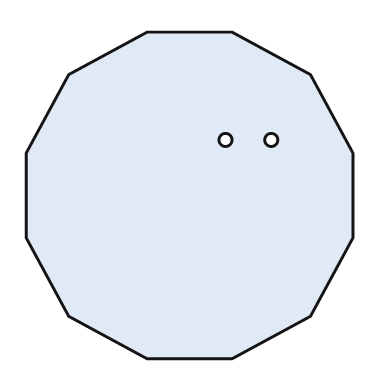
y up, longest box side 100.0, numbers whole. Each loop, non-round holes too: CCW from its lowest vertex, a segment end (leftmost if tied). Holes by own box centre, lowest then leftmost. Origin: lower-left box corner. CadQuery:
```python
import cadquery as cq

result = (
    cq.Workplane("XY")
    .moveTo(37.0, 0.0)
    .lineTo(63.0, 0.0)
    .lineTo(87.0, 13.0)
    .lineTo(100.0, 37.0)
    .lineTo(100.0, 63.0)
    .lineTo(87.0, 87.0)
    .lineTo(63.0, 100.0)
    .lineTo(37.0, 100.0)
    .lineTo(13.0, 87.0)
    .lineTo(0.0, 63.0)
    .lineTo(0.0, 37.0)
    .lineTo(13.0, 13.0)
    .close()
    .moveTo(61.0, 67.0)
    .circle(2.0)
    .moveTo(75.0, 67.0)
    .circle(2.0)
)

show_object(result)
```